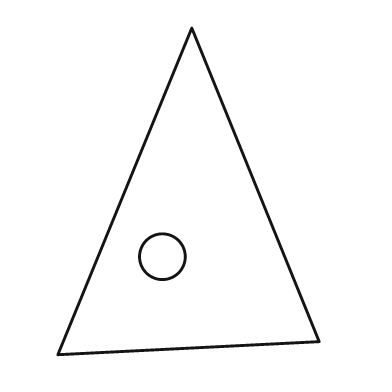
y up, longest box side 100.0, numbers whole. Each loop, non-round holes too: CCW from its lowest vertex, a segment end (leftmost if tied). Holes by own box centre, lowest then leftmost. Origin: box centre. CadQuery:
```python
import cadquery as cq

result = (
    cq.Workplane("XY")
    .moveTo(-40.0, -50.0)
    .lineTo(40.0, -46.0)
    .lineTo(1.0, 50.0)
    .close()
    .moveTo(-8.0, -20.0)
    .circle(7.0)
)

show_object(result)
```